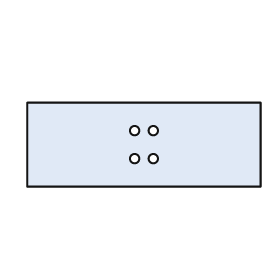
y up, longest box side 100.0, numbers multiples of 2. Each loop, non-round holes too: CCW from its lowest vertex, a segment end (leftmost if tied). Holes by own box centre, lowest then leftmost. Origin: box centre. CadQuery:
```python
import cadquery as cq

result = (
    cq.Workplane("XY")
    .moveTo(-50.0, -18.0)
    .lineTo(50.0, -18.0)
    .lineTo(50.0, 18.0)
    .lineTo(-50.0, 18.0)
    .close()
    .moveTo(-4.0, -6.0)
    .circle(2.0)
    .moveTo(4.0, -6.0)
    .circle(2.0)
    .moveTo(-4.0, 6.0)
    .circle(2.0)
    .moveTo(4.0, 6.0)
    .circle(2.0)
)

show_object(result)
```